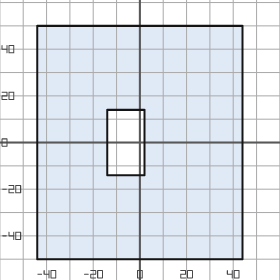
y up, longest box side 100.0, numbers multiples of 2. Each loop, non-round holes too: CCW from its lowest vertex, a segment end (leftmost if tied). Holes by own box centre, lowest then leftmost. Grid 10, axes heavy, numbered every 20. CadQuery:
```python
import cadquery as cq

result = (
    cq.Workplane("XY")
    .moveTo(-44.0, -50.0)
    .lineTo(44.0, -50.0)
    .lineTo(44.0, 50.0)
    .lineTo(-44.0, 50.0)
    .close()
    .moveTo(-14.0, -14.0)
    .lineTo(2.0, -14.0)
    .lineTo(2.0, 14.0)
    .lineTo(-14.0, 14.0)
    .close()
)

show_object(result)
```